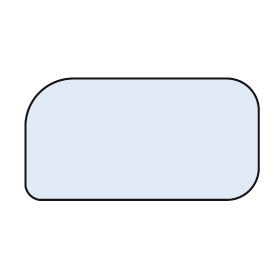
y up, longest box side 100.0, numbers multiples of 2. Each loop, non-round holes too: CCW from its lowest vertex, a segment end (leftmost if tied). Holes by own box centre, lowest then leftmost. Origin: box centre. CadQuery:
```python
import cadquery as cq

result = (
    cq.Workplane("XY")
    .moveTo(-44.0, -26.0)
    .lineTo(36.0, -26.0)
    .threePointArc((46.0, -22.0), (50.0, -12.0))
    .lineTo(50.0, 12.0)
    .threePointArc((46.0, 22.0), (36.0, 26.0))
    .lineTo(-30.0, 26.0)
    .threePointArc((-44.0, 20.0), (-50.0, 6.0))
    .lineTo(-50.0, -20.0)
    .threePointArc((-48.0, -24.0), (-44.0, -26.0))
    .close()
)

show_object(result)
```